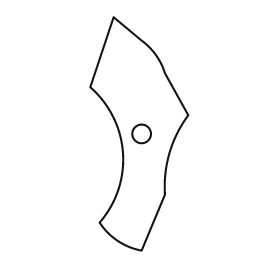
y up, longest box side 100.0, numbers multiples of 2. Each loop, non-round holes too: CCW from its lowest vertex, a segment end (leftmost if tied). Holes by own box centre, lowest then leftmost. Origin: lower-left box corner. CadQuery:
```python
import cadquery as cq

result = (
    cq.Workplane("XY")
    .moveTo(22.0, 0.0)
    .lineTo(32.0, 24.0)
    .threePointArc((34.0, 42.0), (42.0, 58.0))
    .lineTo(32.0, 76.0)
    .threePointArc((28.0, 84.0), (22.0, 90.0))
    .lineTo(10.0, 100.0)
    .lineTo(0.0, 70.0)
    .threePointArc((14.0, 42.0), (4.0, 12.0))
    .threePointArc((12.0, 4.0), (22.0, 0.0))
    .close()
    .moveTo(22.0, 50.0)
    .circle(4.0)
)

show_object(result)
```